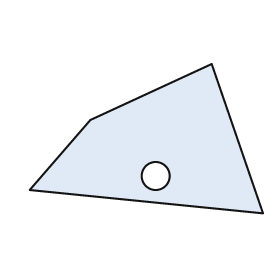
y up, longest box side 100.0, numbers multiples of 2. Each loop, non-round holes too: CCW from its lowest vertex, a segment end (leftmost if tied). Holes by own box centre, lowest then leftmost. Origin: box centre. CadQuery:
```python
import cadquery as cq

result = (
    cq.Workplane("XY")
    .moveTo(50.0, -32.0)
    .lineTo(28.0, 32.0)
    .lineTo(-24.0, 8.0)
    .lineTo(-50.0, -22.0)
    .close()
    .moveTo(4.0, -16.0)
    .circle(6.0)
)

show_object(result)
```